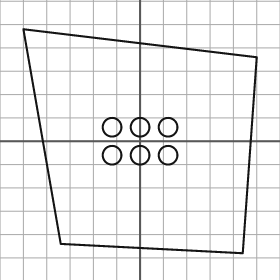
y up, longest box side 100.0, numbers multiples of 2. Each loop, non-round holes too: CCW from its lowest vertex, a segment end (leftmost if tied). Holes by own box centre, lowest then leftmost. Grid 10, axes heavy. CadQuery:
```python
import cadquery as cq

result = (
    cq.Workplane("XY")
    .moveTo(44.0, -48.0)
    .lineTo(50.0, 36.0)
    .lineTo(-50.0, 48.0)
    .lineTo(-34.0, -44.0)
    .close()
    .moveTo(-12.0, -6.0)
    .circle(4.0)
    .moveTo(0.0, -6.0)
    .circle(4.0)
    .moveTo(12.0, -6.0)
    .circle(4.0)
    .moveTo(-12.0, 6.0)
    .circle(4.0)
    .moveTo(0.0, 6.0)
    .circle(4.0)
    .moveTo(12.0, 6.0)
    .circle(4.0)
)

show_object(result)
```